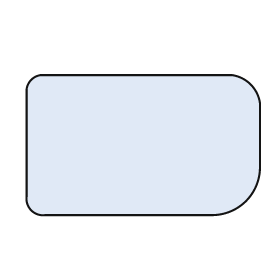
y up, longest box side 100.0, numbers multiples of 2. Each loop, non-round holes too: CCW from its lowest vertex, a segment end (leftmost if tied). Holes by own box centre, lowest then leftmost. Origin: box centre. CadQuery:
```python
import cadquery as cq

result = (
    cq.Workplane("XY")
    .moveTo(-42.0, -30.0)
    .lineTo(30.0, -30.0)
    .threePointArc((44.0, -24.0), (50.0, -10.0))
    .lineTo(50.0, 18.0)
    .threePointArc((46.0, 26.0), (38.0, 30.0))
    .lineTo(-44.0, 30.0)
    .threePointArc((-48.0, 28.0), (-50.0, 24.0))
    .lineTo(-50.0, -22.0)
    .threePointArc((-48.0, -28.0), (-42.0, -30.0))
    .close()
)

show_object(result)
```